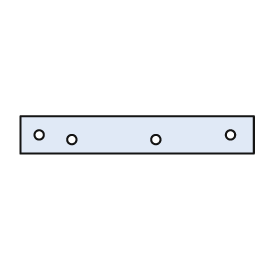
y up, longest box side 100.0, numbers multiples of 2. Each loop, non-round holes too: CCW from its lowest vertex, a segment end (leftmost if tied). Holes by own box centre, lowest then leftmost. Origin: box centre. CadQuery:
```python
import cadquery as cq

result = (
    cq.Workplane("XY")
    .moveTo(-50.0, -8.0)
    .lineTo(50.0, -8.0)
    .lineTo(50.0, 8.0)
    .lineTo(-50.0, 8.0)
    .close()
    .moveTo(-28.0, -2.0)
    .circle(2.0)
    .moveTo(8.0, -2.0)
    .circle(2.0)
    .moveTo(-42.0, 0.0)
    .circle(2.0)
    .moveTo(40.0, 0.0)
    .circle(2.0)
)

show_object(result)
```